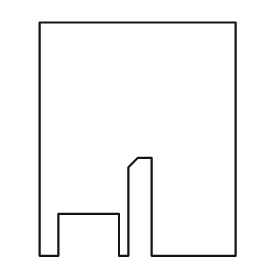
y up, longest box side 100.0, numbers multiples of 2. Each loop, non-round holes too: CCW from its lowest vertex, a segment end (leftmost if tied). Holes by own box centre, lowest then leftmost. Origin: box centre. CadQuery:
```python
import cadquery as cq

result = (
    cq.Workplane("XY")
    .moveTo(-42.0, -50.0)
    .lineTo(-34.0, -50.0)
    .lineTo(-34.0, -32.0)
    .lineTo(-8.0, -32.0)
    .lineTo(-8.0, -50.0)
    .lineTo(-4.0, -50.0)
    .lineTo(-4.0, -12.0)
    .lineTo(0.0, -8.0)
    .lineTo(6.0, -8.0)
    .lineTo(6.0, -50.0)
    .lineTo(42.0, -50.0)
    .lineTo(42.0, 50.0)
    .lineTo(-42.0, 50.0)
    .close()
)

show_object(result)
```